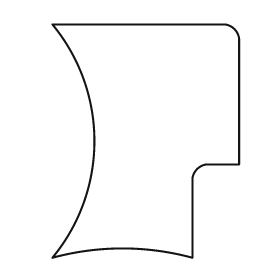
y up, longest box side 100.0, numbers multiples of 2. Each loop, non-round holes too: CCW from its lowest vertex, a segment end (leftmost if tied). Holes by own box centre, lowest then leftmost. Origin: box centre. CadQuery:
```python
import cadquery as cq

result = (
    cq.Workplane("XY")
    .moveTo(-40.0, -50.0)
    .threePointArc((-10.0, -46.0), (20.0, -50.0))
    .lineTo(20.0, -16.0)
    .threePointArc((22.0, -12.0), (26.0, -10.0))
    .lineTo(40.0, -10.0)
    .lineTo(40.0, 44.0)
    .threePointArc((38.0, 48.0), (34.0, 50.0))
    .lineTo(-40.0, 50.0)
    .threePointArc((-22.0, 0.0), (-40.0, -50.0))
    .close()
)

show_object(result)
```